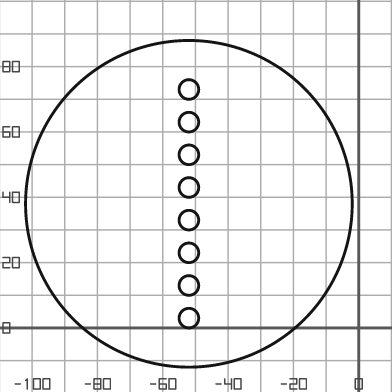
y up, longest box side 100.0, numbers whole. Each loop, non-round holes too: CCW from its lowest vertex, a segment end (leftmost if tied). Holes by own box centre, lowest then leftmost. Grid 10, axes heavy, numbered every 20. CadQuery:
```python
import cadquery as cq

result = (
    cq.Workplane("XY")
    .moveTo(-52.0, 38.0)
    .circle(50.0)
    .moveTo(-52.0, 3.0)
    .circle(3.0)
    .moveTo(-52.0, 13.0)
    .circle(3.0)
    .moveTo(-52.0, 23.0)
    .circle(3.0)
    .moveTo(-52.0, 33.0)
    .circle(3.0)
    .moveTo(-52.0, 43.0)
    .circle(3.0)
    .moveTo(-52.0, 53.0)
    .circle(3.0)
    .moveTo(-52.0, 63.0)
    .circle(3.0)
    .moveTo(-52.0, 73.0)
    .circle(3.0)
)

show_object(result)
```